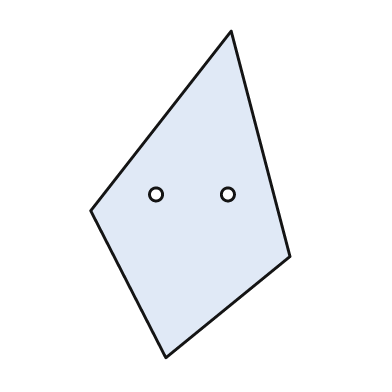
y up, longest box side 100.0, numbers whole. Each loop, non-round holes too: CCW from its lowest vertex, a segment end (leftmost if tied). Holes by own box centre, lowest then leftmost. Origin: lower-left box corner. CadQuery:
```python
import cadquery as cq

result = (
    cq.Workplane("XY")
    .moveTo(23.0, 0.0)
    .lineTo(61.0, 31.0)
    .lineTo(43.0, 100.0)
    .lineTo(0.0, 45.0)
    .close()
    .moveTo(20.0, 50.0)
    .circle(2.0)
    .moveTo(42.0, 50.0)
    .circle(2.0)
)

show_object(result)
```